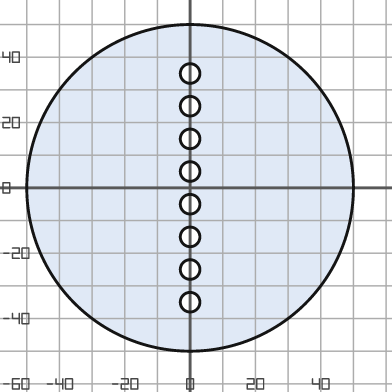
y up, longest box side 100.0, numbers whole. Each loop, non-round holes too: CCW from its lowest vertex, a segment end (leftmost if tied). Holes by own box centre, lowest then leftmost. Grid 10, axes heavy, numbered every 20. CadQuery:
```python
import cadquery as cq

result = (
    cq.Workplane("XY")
    .moveTo(0.0, 0.0)
    .circle(50.0)
    .moveTo(0.0, -35.0)
    .circle(3.0)
    .moveTo(0.0, -25.0)
    .circle(3.0)
    .moveTo(0.0, -15.0)
    .circle(3.0)
    .moveTo(0.0, -5.0)
    .circle(3.0)
    .moveTo(0.0, 5.0)
    .circle(3.0)
    .moveTo(0.0, 15.0)
    .circle(3.0)
    .moveTo(0.0, 25.0)
    .circle(3.0)
    .moveTo(0.0, 35.0)
    .circle(3.0)
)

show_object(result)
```